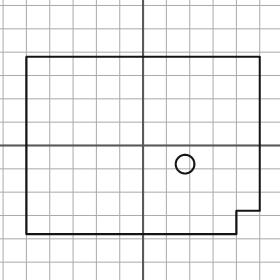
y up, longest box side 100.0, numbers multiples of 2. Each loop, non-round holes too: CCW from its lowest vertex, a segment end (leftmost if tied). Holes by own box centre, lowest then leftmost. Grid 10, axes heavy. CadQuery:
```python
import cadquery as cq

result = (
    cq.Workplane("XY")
    .moveTo(-50.0, -38.0)
    .lineTo(40.0, -38.0)
    .lineTo(40.0, -28.0)
    .lineTo(50.0, -28.0)
    .lineTo(50.0, 38.0)
    .lineTo(-50.0, 38.0)
    .close()
    .moveTo(18.0, -8.0)
    .circle(4.0)
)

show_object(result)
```